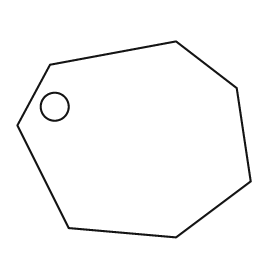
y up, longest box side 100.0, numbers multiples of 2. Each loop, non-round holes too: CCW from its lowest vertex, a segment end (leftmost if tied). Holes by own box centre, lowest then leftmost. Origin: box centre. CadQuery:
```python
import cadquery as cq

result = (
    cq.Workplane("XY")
    .moveTo(18.0, -42.0)
    .lineTo(50.0, -18.0)
    .lineTo(44.0, 22.0)
    .lineTo(18.0, 42.0)
    .lineTo(-36.0, 32.0)
    .lineTo(-50.0, 6.0)
    .lineTo(-28.0, -38.0)
    .close()
    .moveTo(-34.0, 14.0)
    .circle(6.0)
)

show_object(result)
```